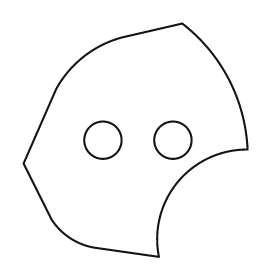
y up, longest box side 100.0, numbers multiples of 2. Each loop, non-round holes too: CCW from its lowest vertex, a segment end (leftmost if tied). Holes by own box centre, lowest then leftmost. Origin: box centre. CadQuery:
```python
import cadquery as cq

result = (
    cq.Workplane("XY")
    .moveTo(10.0, -50.0)
    .threePointArc((18.0, -18.0), (48.0, -4.0))
    .threePointArc((40.0, 26.0), (20.0, 50.0))
    .lineTo(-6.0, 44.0)
    .threePointArc((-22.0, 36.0), (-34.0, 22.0))
    .lineTo(-48.0, -10.0)
    .lineTo(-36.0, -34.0)
    .threePointArc((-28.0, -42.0), (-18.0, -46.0))
    .close()
    .moveTo(-14.0, 0.0)
    .circle(8.0)
    .moveTo(16.0, 0.0)
    .circle(8.0)
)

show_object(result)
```